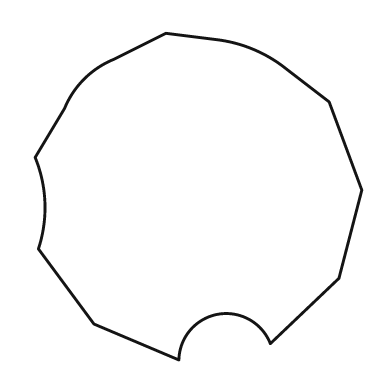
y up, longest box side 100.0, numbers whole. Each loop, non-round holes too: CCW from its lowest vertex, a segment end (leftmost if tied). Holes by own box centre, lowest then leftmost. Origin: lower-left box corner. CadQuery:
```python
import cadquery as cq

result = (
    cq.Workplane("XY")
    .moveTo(44.0, 0.0)
    .threePointArc((56.0, 14.0), (72.0, 5.0))
    .lineTo(93.0, 25.0)
    .lineTo(100.0, 52.0)
    .lineTo(90.0, 79.0)
    .lineTo(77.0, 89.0)
    .threePointArc((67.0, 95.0), (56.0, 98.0))
    .lineTo(40.0, 100.0)
    .lineTo(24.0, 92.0)
    .threePointArc((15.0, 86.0), (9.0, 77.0))
    .lineTo(0.0, 62.0)
    .threePointArc((3.0, 48.0), (1.0, 34.0))
    .lineTo(18.0, 11.0)
    .close()
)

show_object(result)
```